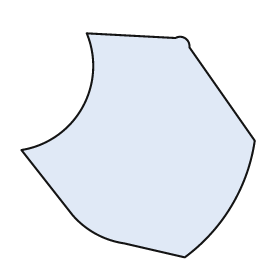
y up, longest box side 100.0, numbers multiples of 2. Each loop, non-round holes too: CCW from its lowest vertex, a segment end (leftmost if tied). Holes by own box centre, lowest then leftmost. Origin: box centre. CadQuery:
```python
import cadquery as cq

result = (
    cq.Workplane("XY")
    .moveTo(20.0, -48.0)
    .threePointArc((40.0, -26.0), (50.0, 2.0))
    .lineTo(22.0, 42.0)
    .threePointArc((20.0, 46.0), (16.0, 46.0))
    .lineTo(-22.0, 48.0)
    .threePointArc((-24.0, 16.0), (-50.0, -2.0))
    .lineTo(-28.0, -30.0)
    .threePointArc((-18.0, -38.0), (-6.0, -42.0))
    .close()
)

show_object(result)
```